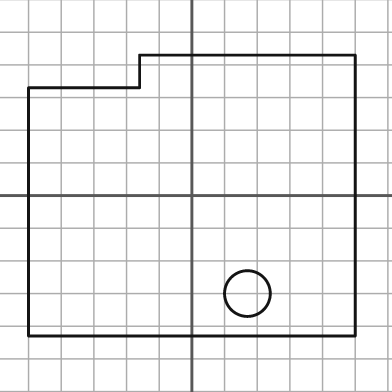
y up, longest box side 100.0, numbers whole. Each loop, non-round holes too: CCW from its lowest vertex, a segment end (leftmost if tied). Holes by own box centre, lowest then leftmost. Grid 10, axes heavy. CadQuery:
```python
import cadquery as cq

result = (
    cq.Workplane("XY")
    .moveTo(-50.0, -43.0)
    .lineTo(50.0, -43.0)
    .lineTo(50.0, 43.0)
    .lineTo(-16.0, 43.0)
    .lineTo(-16.0, 33.0)
    .lineTo(-50.0, 33.0)
    .close()
    .moveTo(17.0, -30.0)
    .circle(7.0)
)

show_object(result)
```